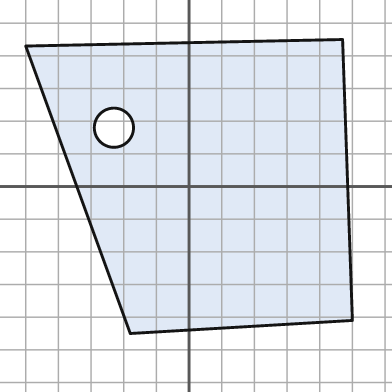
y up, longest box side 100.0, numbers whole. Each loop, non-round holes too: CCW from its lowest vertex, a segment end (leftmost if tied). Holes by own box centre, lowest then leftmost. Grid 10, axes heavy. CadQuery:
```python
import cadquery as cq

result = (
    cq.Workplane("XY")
    .moveTo(-18.0, -45.0)
    .lineTo(50.0, -41.0)
    .lineTo(47.0, 45.0)
    .lineTo(-50.0, 43.0)
    .close()
    .moveTo(-23.0, 18.0)
    .circle(6.0)
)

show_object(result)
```